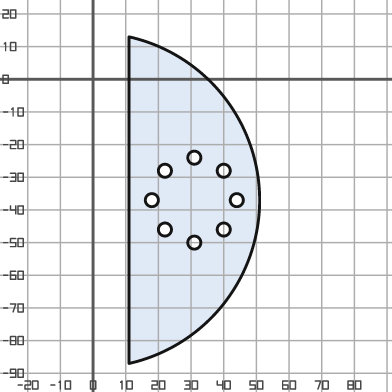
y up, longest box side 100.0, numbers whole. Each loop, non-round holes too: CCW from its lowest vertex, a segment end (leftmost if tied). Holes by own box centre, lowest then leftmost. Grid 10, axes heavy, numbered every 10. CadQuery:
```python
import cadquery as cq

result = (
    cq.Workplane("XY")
    .moveTo(11.0, -87.0)
    .threePointArc((51.0, -37.0), (11.0, 13.0))
    .close()
    .moveTo(31.0, -50.0)
    .circle(2.0)
    .moveTo(22.0, -46.0)
    .circle(2.0)
    .moveTo(40.0, -46.0)
    .circle(2.0)
    .moveTo(18.0, -37.0)
    .circle(2.0)
    .moveTo(44.0, -37.0)
    .circle(2.0)
    .moveTo(22.0, -28.0)
    .circle(2.0)
    .moveTo(40.0, -28.0)
    .circle(2.0)
    .moveTo(31.0, -24.0)
    .circle(2.0)
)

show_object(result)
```